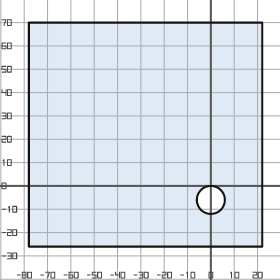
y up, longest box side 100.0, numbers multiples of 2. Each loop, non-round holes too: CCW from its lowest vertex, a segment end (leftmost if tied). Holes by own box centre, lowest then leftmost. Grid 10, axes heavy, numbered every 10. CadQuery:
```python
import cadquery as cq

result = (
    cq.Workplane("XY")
    .moveTo(-78.0, -26.0)
    .lineTo(22.0, -26.0)
    .lineTo(22.0, 70.0)
    .lineTo(-78.0, 70.0)
    .close()
    .moveTo(0.0, -6.0)
    .circle(6.0)
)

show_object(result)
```